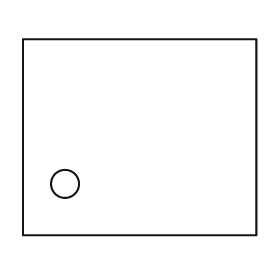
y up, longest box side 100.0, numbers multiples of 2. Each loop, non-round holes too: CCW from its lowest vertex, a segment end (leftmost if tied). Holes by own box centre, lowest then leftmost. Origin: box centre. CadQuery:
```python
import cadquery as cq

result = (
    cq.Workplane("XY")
    .moveTo(-50.0, -42.0)
    .lineTo(50.0, -42.0)
    .lineTo(50.0, 42.0)
    .lineTo(-50.0, 42.0)
    .close()
    .moveTo(-32.0, -20.0)
    .circle(6.0)
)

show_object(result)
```